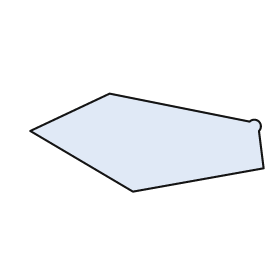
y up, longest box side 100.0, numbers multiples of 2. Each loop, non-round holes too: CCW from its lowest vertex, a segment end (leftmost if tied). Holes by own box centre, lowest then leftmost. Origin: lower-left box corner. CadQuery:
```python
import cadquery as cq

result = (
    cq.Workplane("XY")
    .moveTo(44.0, 0.0)
    .lineTo(100.0, 10.0)
    .lineTo(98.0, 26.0)
    .threePointArc((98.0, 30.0), (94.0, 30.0))
    .lineTo(34.0, 42.0)
    .lineTo(0.0, 26.0)
    .close()
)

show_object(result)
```